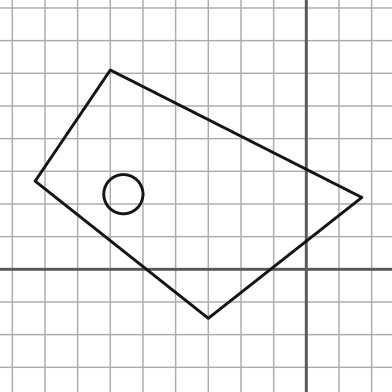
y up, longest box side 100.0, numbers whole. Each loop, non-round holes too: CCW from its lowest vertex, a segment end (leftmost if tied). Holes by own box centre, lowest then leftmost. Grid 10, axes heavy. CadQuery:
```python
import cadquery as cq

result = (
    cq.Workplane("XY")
    .moveTo(-30.0, -15.0)
    .lineTo(17.0, 22.0)
    .lineTo(-60.0, 61.0)
    .lineTo(-83.0, 27.0)
    .close()
    .moveTo(-56.0, 23.0)
    .circle(6.0)
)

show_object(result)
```